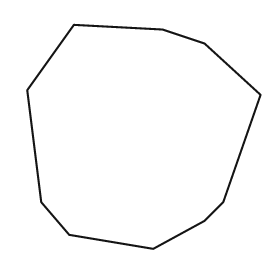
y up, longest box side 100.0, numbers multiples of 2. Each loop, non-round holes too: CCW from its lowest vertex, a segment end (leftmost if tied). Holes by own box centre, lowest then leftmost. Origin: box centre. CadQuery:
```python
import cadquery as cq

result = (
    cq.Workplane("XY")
    .moveTo(4.0, -48.0)
    .lineTo(26.0, -36.0)
    .lineTo(34.0, -28.0)
    .lineTo(50.0, 18.0)
    .lineTo(26.0, 40.0)
    .lineTo(8.0, 46.0)
    .lineTo(-30.0, 48.0)
    .lineTo(-50.0, 20.0)
    .lineTo(-44.0, -28.0)
    .lineTo(-32.0, -42.0)
    .close()
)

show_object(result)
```